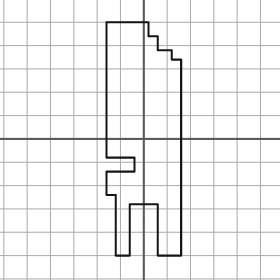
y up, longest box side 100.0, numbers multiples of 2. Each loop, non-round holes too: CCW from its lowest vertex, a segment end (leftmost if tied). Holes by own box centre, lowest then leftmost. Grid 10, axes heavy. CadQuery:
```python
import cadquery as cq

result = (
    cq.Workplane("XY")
    .moveTo(-12.0, -50.0)
    .lineTo(-6.0, -50.0)
    .lineTo(-6.0, -28.0)
    .lineTo(6.0, -28.0)
    .lineTo(6.0, -50.0)
    .lineTo(16.0, -50.0)
    .lineTo(16.0, 34.0)
    .lineTo(12.0, 34.0)
    .lineTo(12.0, 38.0)
    .lineTo(6.0, 38.0)
    .lineTo(6.0, 44.0)
    .lineTo(2.0, 44.0)
    .lineTo(2.0, 50.0)
    .lineTo(-16.0, 50.0)
    .lineTo(-16.0, -8.0)
    .lineTo(-4.0, -8.0)
    .lineTo(-4.0, -14.0)
    .lineTo(-16.0, -14.0)
    .lineTo(-16.0, -24.0)
    .lineTo(-12.0, -24.0)
    .close()
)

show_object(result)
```